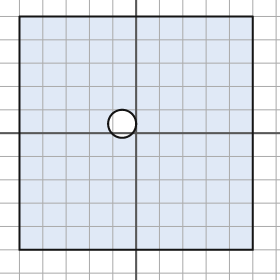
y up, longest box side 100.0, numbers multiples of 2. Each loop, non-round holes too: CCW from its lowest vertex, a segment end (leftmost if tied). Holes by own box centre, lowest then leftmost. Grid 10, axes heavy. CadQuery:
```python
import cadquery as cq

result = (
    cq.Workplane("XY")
    .moveTo(-50.0, -50.0)
    .lineTo(50.0, -50.0)
    .lineTo(50.0, 50.0)
    .lineTo(-50.0, 50.0)
    .close()
    .moveTo(-6.0, 4.0)
    .circle(6.0)
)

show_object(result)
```